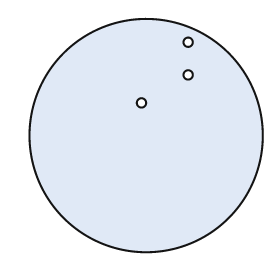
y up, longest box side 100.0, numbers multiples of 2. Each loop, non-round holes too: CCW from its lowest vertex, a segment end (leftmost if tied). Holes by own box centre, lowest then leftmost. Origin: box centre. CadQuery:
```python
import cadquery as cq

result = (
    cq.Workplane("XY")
    .moveTo(0.0, 0.0)
    .circle(50.0)
    .moveTo(-2.0, 14.0)
    .circle(2.0)
    .moveTo(18.0, 26.0)
    .circle(2.0)
    .moveTo(18.0, 40.0)
    .circle(2.0)
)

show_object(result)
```